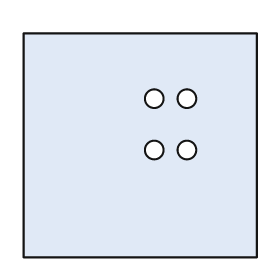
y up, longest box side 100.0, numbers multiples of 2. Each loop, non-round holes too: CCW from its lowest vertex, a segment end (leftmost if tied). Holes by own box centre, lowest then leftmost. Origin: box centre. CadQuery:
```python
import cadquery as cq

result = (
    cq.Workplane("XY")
    .moveTo(-50.0, -48.0)
    .lineTo(50.0, -48.0)
    .lineTo(50.0, 48.0)
    .lineTo(-50.0, 48.0)
    .close()
    .moveTo(6.0, -2.0)
    .circle(4.0)
    .moveTo(20.0, -2.0)
    .circle(4.0)
    .moveTo(6.0, 20.0)
    .circle(4.0)
    .moveTo(20.0, 20.0)
    .circle(4.0)
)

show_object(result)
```